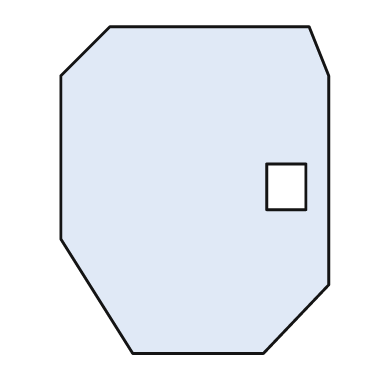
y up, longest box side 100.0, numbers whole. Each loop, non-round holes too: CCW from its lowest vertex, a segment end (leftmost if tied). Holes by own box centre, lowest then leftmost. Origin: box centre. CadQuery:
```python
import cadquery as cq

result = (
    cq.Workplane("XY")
    .moveTo(-19.0, -50.0)
    .lineTo(21.0, -50.0)
    .lineTo(41.0, -29.0)
    .lineTo(41.0, 35.0)
    .lineTo(35.0, 50.0)
    .lineTo(-26.0, 50.0)
    .lineTo(-41.0, 35.0)
    .lineTo(-41.0, -15.0)
    .close()
    .moveTo(22.0, -6.0)
    .lineTo(34.0, -6.0)
    .lineTo(34.0, 8.0)
    .lineTo(22.0, 8.0)
    .close()
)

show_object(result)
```